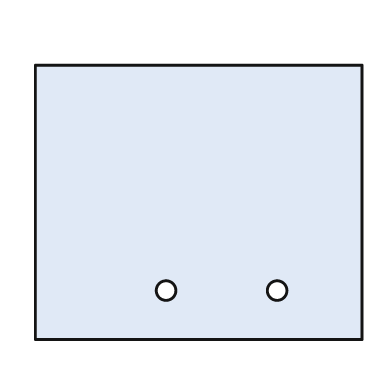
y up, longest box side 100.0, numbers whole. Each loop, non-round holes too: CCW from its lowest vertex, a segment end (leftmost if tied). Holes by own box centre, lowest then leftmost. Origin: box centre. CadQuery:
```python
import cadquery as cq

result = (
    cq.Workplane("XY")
    .moveTo(-50.0, -42.0)
    .lineTo(50.0, -42.0)
    .lineTo(50.0, 42.0)
    .lineTo(-50.0, 42.0)
    .close()
    .moveTo(-10.0, -27.0)
    .circle(3.0)
    .moveTo(24.0, -27.0)
    .circle(3.0)
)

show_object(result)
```